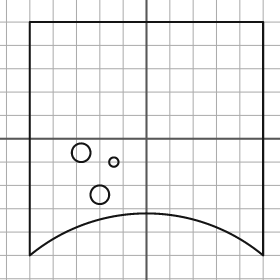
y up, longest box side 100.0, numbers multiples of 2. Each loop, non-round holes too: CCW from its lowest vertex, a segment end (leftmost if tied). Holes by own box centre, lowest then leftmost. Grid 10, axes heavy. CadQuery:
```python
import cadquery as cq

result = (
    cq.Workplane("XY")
    .moveTo(-50.0, -50.0)
    .threePointArc((0.0, -32.0), (50.0, -50.0))
    .lineTo(50.0, 50.0)
    .lineTo(-50.0, 50.0)
    .close()
    .moveTo(-20.0, -24.0)
    .circle(4.0)
    .moveTo(-14.0, -10.0)
    .circle(2.0)
    .moveTo(-28.0, -6.0)
    .circle(4.0)
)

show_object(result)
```